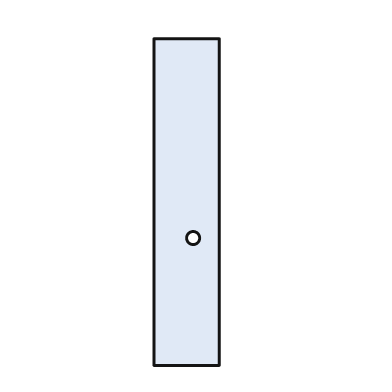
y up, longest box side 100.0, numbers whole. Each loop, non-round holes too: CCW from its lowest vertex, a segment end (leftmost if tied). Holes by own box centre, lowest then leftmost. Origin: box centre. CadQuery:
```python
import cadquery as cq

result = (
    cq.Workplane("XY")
    .moveTo(-10.0, -50.0)
    .lineTo(10.0, -50.0)
    .lineTo(10.0, 50.0)
    .lineTo(-10.0, 50.0)
    .close()
    .moveTo(2.0, -11.0)
    .circle(2.0)
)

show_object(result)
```